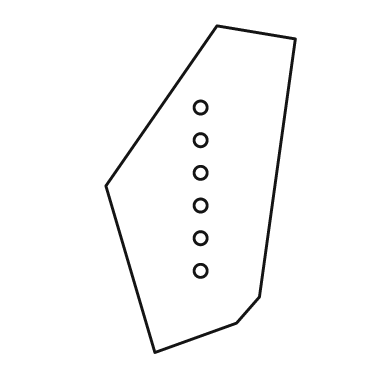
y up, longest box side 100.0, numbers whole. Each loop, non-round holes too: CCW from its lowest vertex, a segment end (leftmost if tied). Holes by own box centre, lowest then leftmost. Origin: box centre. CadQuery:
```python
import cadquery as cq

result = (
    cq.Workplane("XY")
    .moveTo(-14.0, -50.0)
    .lineTo(11.0, -41.0)
    .lineTo(18.0, -33.0)
    .lineTo(29.0, 46.0)
    .lineTo(5.0, 50.0)
    .lineTo(-29.0, 1.0)
    .close()
    .moveTo(0.0, -25.0)
    .circle(2.0)
    .moveTo(0.0, -15.0)
    .circle(2.0)
    .moveTo(0.0, -5.0)
    .circle(2.0)
    .moveTo(0.0, 5.0)
    .circle(2.0)
    .moveTo(0.0, 15.0)
    .circle(2.0)
    .moveTo(0.0, 25.0)
    .circle(2.0)
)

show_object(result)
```